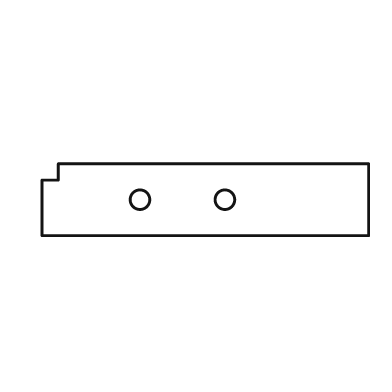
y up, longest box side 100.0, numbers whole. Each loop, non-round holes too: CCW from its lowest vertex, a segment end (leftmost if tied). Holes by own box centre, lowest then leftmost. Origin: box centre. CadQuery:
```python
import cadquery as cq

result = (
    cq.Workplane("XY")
    .moveTo(-50.0, -11.0)
    .lineTo(50.0, -11.0)
    .lineTo(50.0, 11.0)
    .lineTo(-45.0, 11.0)
    .lineTo(-45.0, 6.0)
    .lineTo(-50.0, 6.0)
    .close()
    .moveTo(-20.0, 0.0)
    .circle(3.0)
    .moveTo(6.0, 0.0)
    .circle(3.0)
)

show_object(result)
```